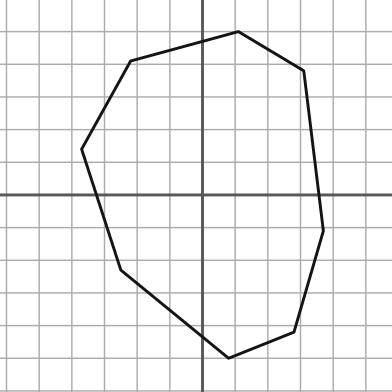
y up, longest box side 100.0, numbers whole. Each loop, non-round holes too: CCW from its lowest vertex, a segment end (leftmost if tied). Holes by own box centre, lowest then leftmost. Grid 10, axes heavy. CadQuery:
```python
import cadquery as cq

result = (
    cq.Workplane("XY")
    .moveTo(8.0, -50.0)
    .lineTo(28.0, -42.0)
    .lineTo(37.0, -11.0)
    .lineTo(31.0, 38.0)
    .lineTo(11.0, 50.0)
    .lineTo(-22.0, 41.0)
    .lineTo(-37.0, 14.0)
    .lineTo(-25.0, -23.0)
    .close()
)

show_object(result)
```